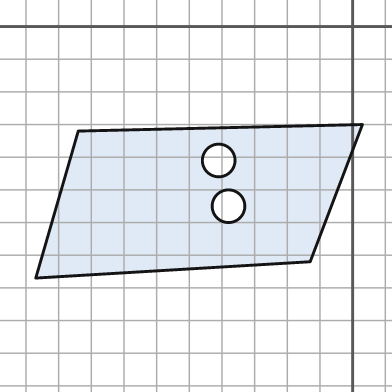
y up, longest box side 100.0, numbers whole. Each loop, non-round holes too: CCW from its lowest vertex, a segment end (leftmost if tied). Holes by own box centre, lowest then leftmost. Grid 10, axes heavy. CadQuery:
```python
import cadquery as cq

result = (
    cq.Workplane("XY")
    .moveTo(-97.0, -77.0)
    .lineTo(-13.0, -72.0)
    .lineTo(3.0, -30.0)
    .lineTo(-84.0, -32.0)
    .close()
    .moveTo(-38.0, -55.0)
    .circle(5.0)
    .moveTo(-41.0, -41.0)
    .circle(5.0)
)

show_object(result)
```